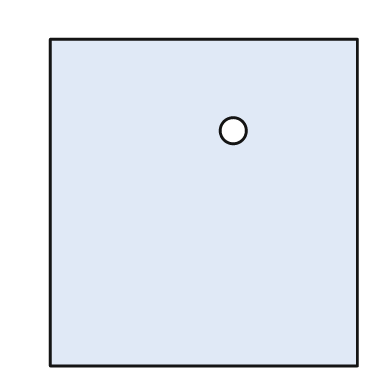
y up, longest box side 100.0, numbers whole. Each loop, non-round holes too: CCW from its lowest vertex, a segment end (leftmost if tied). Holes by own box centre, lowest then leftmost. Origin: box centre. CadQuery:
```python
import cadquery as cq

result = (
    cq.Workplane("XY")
    .moveTo(-47.0, -50.0)
    .lineTo(47.0, -50.0)
    .lineTo(47.0, 50.0)
    .lineTo(-47.0, 50.0)
    .close()
    .moveTo(9.0, 22.0)
    .circle(4.0)
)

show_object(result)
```